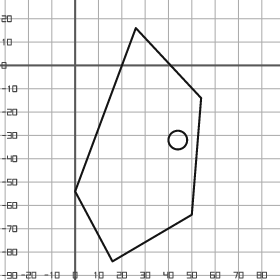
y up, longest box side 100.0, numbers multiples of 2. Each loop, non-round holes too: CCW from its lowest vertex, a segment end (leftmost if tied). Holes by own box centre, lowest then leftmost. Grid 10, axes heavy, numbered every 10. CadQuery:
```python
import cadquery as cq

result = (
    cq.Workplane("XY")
    .moveTo(16.0, -84.0)
    .lineTo(50.0, -64.0)
    .lineTo(54.0, -14.0)
    .lineTo(26.0, 16.0)
    .lineTo(0.0, -54.0)
    .close()
    .moveTo(44.0, -32.0)
    .circle(4.0)
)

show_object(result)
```